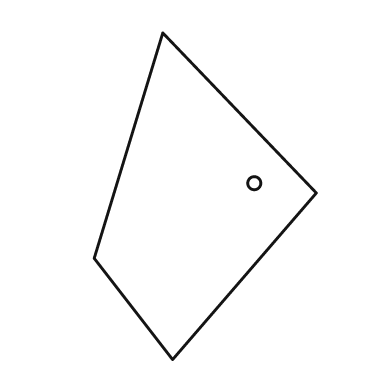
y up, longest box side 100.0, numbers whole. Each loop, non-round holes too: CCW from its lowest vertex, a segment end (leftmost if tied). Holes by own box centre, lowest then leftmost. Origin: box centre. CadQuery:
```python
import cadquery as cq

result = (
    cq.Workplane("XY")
    .moveTo(-10.0, -50.0)
    .lineTo(34.0, 1.0)
    .lineTo(-13.0, 50.0)
    .lineTo(-34.0, -19.0)
    .close()
    .moveTo(15.0, 4.0)
    .circle(2.0)
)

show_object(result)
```